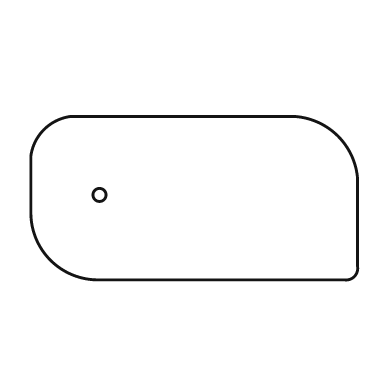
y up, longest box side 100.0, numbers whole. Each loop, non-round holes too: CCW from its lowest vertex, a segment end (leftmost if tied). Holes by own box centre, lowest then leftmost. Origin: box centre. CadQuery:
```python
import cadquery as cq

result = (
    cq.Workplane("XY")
    .moveTo(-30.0, -25.0)
    .lineTo(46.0, -25.0)
    .threePointArc((49.0, -24.0), (50.0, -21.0))
    .lineTo(50.0, 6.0)
    .threePointArc((44.0, 19.0), (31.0, 25.0))
    .lineTo(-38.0, 25.0)
    .threePointArc((-46.0, 21.0), (-50.0, 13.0))
    .lineTo(-50.0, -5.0)
    .threePointArc((-44.0, -19.0), (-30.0, -25.0))
    .close()
    .moveTo(-29.0, 1.0)
    .circle(2.0)
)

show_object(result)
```